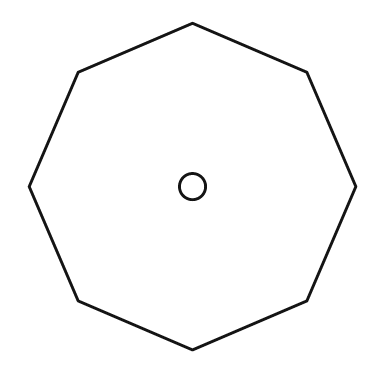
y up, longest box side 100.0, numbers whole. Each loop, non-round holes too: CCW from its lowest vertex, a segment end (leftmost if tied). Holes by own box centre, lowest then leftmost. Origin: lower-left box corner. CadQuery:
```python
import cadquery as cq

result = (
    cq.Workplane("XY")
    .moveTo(50.0, 0.0)
    .lineTo(85.0, 15.0)
    .lineTo(100.0, 50.0)
    .lineTo(85.0, 85.0)
    .lineTo(50.0, 100.0)
    .lineTo(15.0, 85.0)
    .lineTo(0.0, 50.0)
    .lineTo(15.0, 15.0)
    .close()
    .moveTo(50.0, 50.0)
    .circle(4.0)
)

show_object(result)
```